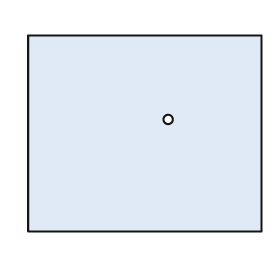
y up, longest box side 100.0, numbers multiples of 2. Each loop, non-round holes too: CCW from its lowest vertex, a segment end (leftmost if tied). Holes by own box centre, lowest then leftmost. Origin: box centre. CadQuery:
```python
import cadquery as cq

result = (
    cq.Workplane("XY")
    .moveTo(-50.0, -42.0)
    .lineTo(50.0, -42.0)
    .lineTo(50.0, 42.0)
    .lineTo(-50.0, 42.0)
    .close()
    .moveTo(10.0, 6.0)
    .circle(2.0)
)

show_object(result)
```